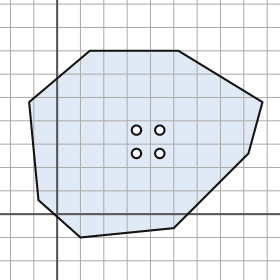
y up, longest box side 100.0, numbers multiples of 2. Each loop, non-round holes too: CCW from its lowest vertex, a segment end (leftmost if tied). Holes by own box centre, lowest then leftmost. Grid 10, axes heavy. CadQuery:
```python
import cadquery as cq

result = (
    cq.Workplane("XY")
    .moveTo(10.0, -10.0)
    .lineTo(50.0, -6.0)
    .lineTo(82.0, 26.0)
    .lineTo(88.0, 48.0)
    .lineTo(52.0, 70.0)
    .lineTo(14.0, 70.0)
    .lineTo(-12.0, 48.0)
    .lineTo(-8.0, 6.0)
    .close()
    .moveTo(34.0, 26.0)
    .circle(2.0)
    .moveTo(44.0, 26.0)
    .circle(2.0)
    .moveTo(34.0, 36.0)
    .circle(2.0)
    .moveTo(44.0, 36.0)
    .circle(2.0)
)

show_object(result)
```